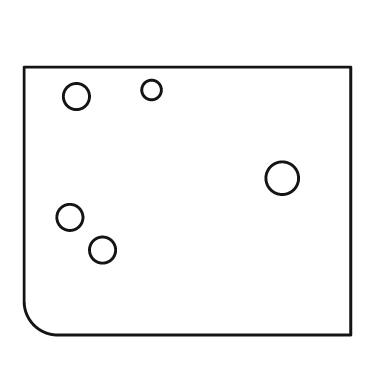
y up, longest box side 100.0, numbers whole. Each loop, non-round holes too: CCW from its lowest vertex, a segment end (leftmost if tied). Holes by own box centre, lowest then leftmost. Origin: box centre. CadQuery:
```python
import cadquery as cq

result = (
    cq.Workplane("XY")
    .moveTo(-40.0, -41.0)
    .lineTo(50.0, -41.0)
    .lineTo(50.0, 41.0)
    .lineTo(-50.0, 41.0)
    .lineTo(-50.0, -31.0)
    .threePointArc((-47.0, -38.0), (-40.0, -41.0))
    .close()
    .moveTo(-26.0, -15.0)
    .circle(4.0)
    .moveTo(-36.0, -5.0)
    .circle(4.0)
    .moveTo(29.0, 7.0)
    .circle(5.0)
    .moveTo(-34.0, 32.0)
    .circle(4.0)
    .moveTo(-11.0, 34.0)
    .circle(3.0)
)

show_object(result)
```